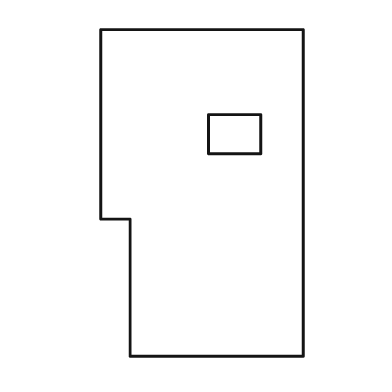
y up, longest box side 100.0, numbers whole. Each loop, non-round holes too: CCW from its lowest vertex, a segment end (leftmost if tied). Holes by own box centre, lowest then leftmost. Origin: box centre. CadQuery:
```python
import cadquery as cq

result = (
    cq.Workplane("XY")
    .moveTo(-22.0, -50.0)
    .lineTo(31.0, -50.0)
    .lineTo(31.0, 50.0)
    .lineTo(-31.0, 50.0)
    .lineTo(-31.0, -8.0)
    .lineTo(-22.0, -8.0)
    .close()
    .moveTo(2.0, 12.0)
    .lineTo(18.0, 12.0)
    .lineTo(18.0, 24.0)
    .lineTo(2.0, 24.0)
    .close()
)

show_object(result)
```